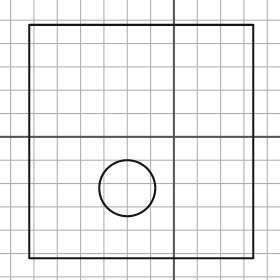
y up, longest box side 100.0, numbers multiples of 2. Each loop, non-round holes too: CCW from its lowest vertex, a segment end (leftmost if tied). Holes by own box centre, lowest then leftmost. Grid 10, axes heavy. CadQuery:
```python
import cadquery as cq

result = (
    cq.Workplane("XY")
    .moveTo(-62.0, -52.0)
    .lineTo(34.0, -52.0)
    .lineTo(34.0, 48.0)
    .lineTo(-62.0, 48.0)
    .close()
    .moveTo(-20.0, -22.0)
    .circle(12.0)
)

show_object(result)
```